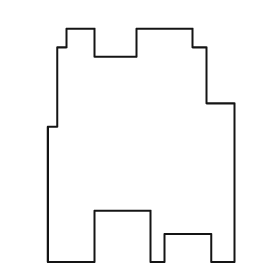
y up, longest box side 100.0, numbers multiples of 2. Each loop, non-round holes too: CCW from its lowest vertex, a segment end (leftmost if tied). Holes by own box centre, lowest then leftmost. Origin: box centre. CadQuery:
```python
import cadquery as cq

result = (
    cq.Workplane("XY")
    .moveTo(-40.0, -50.0)
    .lineTo(-20.0, -50.0)
    .lineTo(-20.0, -28.0)
    .lineTo(4.0, -28.0)
    .lineTo(4.0, -50.0)
    .lineTo(10.0, -50.0)
    .lineTo(10.0, -38.0)
    .lineTo(30.0, -38.0)
    .lineTo(30.0, -50.0)
    .lineTo(40.0, -50.0)
    .lineTo(40.0, 18.0)
    .lineTo(28.0, 18.0)
    .lineTo(28.0, 42.0)
    .lineTo(22.0, 42.0)
    .lineTo(22.0, 50.0)
    .lineTo(-2.0, 50.0)
    .lineTo(-2.0, 38.0)
    .lineTo(-20.0, 38.0)
    .lineTo(-20.0, 50.0)
    .lineTo(-32.0, 50.0)
    .lineTo(-32.0, 42.0)
    .lineTo(-36.0, 42.0)
    .lineTo(-36.0, 8.0)
    .lineTo(-40.0, 8.0)
    .close()
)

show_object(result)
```